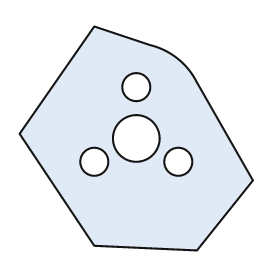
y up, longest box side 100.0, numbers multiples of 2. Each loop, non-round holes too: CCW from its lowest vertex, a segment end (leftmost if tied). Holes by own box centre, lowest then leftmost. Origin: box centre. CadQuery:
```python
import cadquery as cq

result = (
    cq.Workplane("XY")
    .moveTo(26.0, -48.0)
    .lineTo(50.0, -18.0)
    .lineTo(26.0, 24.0)
    .threePointArc((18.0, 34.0), (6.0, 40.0))
    .lineTo(-18.0, 48.0)
    .lineTo(-50.0, 2.0)
    .lineTo(-18.0, -46.0)
    .close()
    .moveTo(-18.0, -10.0)
    .circle(6.0)
    .moveTo(18.0, -10.0)
    .circle(6.0)
    .moveTo(0.0, 0.0)
    .circle(10.0)
    .moveTo(0.0, 22.0)
    .circle(6.0)
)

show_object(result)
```